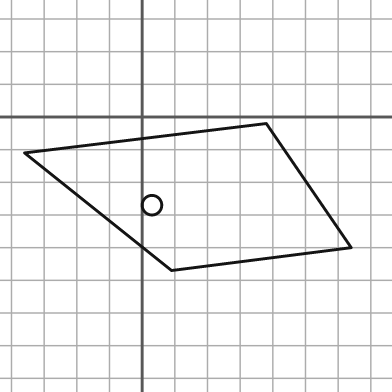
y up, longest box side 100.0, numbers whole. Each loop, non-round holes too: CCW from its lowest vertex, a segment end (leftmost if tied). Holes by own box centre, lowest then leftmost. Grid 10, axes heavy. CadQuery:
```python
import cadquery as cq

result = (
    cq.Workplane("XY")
    .moveTo(9.0, -47.0)
    .lineTo(64.0, -40.0)
    .lineTo(38.0, -2.0)
    .lineTo(-36.0, -11.0)
    .close()
    .moveTo(3.0, -27.0)
    .circle(3.0)
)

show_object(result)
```